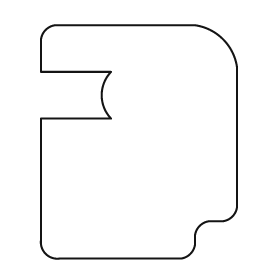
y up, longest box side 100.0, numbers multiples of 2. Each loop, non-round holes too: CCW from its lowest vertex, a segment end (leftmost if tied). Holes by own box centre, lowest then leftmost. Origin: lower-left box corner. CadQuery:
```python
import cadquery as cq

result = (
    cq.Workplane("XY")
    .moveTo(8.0, 0.0)
    .lineTo(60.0, 0.0)
    .threePointArc((64.0, 2.0), (66.0, 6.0))
    .lineTo(66.0, 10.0)
    .threePointArc((68.0, 14.0), (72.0, 16.0))
    .lineTo(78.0, 16.0)
    .threePointArc((82.0, 18.0), (84.0, 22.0))
    .lineTo(84.0, 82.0)
    .threePointArc((78.0, 94.0), (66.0, 100.0))
    .lineTo(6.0, 100.0)
    .threePointArc((2.0, 98.0), (0.0, 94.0))
    .lineTo(0.0, 80.0)
    .lineTo(30.0, 80.0)
    .threePointArc((26.0, 70.0), (30.0, 60.0))
    .lineTo(0.0, 60.0)
    .lineTo(0.0, 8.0)
    .threePointArc((2.0, 2.0), (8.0, 0.0))
    .close()
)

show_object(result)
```